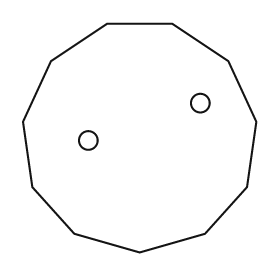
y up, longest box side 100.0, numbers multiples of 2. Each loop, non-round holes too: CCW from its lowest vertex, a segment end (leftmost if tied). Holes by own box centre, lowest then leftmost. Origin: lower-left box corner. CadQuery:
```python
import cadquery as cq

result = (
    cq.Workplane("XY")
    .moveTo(50.0, 0.0)
    .lineTo(78.0, 8.0)
    .lineTo(96.0, 28.0)
    .lineTo(100.0, 56.0)
    .lineTo(88.0, 82.0)
    .lineTo(64.0, 98.0)
    .lineTo(36.0, 98.0)
    .lineTo(12.0, 82.0)
    .lineTo(0.0, 56.0)
    .lineTo(4.0, 28.0)
    .lineTo(22.0, 8.0)
    .close()
    .moveTo(28.0, 48.0)
    .circle(4.0)
    .moveTo(76.0, 64.0)
    .circle(4.0)
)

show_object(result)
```